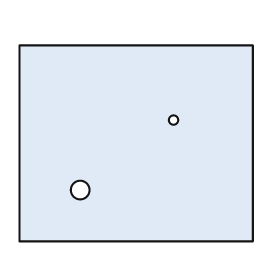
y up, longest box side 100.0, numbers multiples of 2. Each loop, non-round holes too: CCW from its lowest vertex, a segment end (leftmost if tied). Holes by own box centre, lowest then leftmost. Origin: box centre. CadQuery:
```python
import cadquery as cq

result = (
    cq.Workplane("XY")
    .moveTo(-50.0, -42.0)
    .lineTo(50.0, -42.0)
    .lineTo(50.0, 42.0)
    .lineTo(-50.0, 42.0)
    .close()
    .moveTo(-24.0, -20.0)
    .circle(4.0)
    .moveTo(16.0, 10.0)
    .circle(2.0)
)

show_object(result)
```